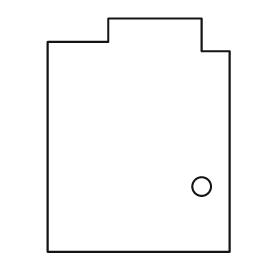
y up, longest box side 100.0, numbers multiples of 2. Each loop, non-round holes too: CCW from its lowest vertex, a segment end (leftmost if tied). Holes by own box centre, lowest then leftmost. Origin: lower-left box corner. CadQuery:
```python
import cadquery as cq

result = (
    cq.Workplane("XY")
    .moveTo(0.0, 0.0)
    .lineTo(78.0, 0.0)
    .lineTo(78.0, 86.0)
    .lineTo(66.0, 86.0)
    .lineTo(66.0, 100.0)
    .lineTo(26.0, 100.0)
    .lineTo(26.0, 90.0)
    .lineTo(0.0, 90.0)
    .close()
    .moveTo(66.0, 28.0)
    .circle(4.0)
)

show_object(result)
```